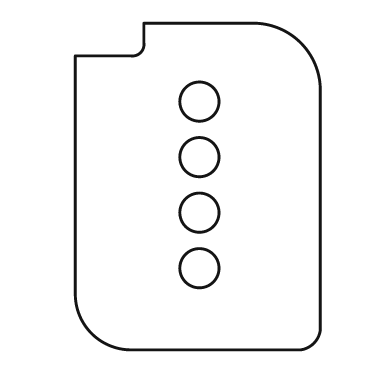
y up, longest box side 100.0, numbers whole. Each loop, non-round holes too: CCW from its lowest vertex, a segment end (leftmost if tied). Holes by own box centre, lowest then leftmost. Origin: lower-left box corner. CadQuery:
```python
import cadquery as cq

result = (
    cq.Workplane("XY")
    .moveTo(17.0, 0.0)
    .lineTo(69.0, 0.0)
    .threePointArc((73.0, 2.0), (75.0, 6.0))
    .lineTo(75.0, 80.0)
    .threePointArc((69.0, 94.0), (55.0, 100.0))
    .lineTo(21.0, 100.0)
    .lineTo(21.0, 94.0)
    .threePointArc((20.0, 91.0), (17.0, 90.0))
    .lineTo(0.0, 90.0)
    .lineTo(0.0, 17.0)
    .threePointArc((5.0, 5.0), (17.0, 0.0))
    .close()
    .moveTo(38.0, 25.0)
    .circle(6.0)
    .moveTo(38.0, 42.0)
    .circle(6.0)
    .moveTo(38.0, 59.0)
    .circle(6.0)
    .moveTo(38.0, 76.0)
    .circle(6.0)
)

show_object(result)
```